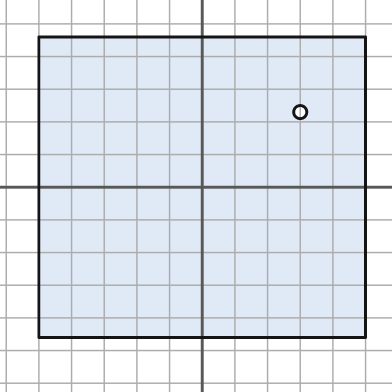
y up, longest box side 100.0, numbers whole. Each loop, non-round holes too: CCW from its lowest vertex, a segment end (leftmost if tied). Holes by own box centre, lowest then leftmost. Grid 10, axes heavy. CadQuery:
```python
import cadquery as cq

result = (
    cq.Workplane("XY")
    .moveTo(-50.0, -46.0)
    .lineTo(50.0, -46.0)
    .lineTo(50.0, 46.0)
    .lineTo(-50.0, 46.0)
    .close()
    .moveTo(30.0, 23.0)
    .circle(2.0)
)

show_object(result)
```